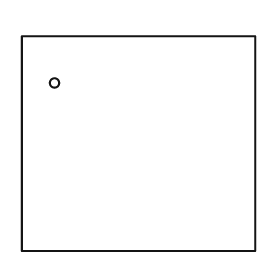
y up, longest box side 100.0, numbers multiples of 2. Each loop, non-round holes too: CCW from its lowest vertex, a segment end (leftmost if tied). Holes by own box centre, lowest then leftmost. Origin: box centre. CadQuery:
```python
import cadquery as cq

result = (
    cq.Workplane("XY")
    .moveTo(-50.0, -46.0)
    .lineTo(50.0, -46.0)
    .lineTo(50.0, 46.0)
    .lineTo(-50.0, 46.0)
    .close()
    .moveTo(-36.0, 26.0)
    .circle(2.0)
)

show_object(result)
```